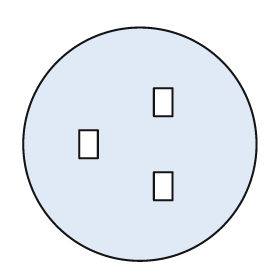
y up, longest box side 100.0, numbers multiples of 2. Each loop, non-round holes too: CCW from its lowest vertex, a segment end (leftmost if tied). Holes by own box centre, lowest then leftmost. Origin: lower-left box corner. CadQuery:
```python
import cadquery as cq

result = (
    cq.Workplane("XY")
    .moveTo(50.0, 50.0)
    .circle(50.0)
    .moveTo(56.0, 26.0)
    .lineTo(64.0, 26.0)
    .lineTo(64.0, 38.0)
    .lineTo(56.0, 38.0)
    .close()
    .moveTo(24.0, 44.0)
    .lineTo(32.0, 44.0)
    .lineTo(32.0, 56.0)
    .lineTo(24.0, 56.0)
    .close()
    .moveTo(56.0, 62.0)
    .lineTo(64.0, 62.0)
    .lineTo(64.0, 74.0)
    .lineTo(56.0, 74.0)
    .close()
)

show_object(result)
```